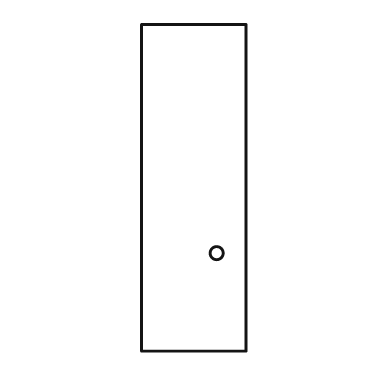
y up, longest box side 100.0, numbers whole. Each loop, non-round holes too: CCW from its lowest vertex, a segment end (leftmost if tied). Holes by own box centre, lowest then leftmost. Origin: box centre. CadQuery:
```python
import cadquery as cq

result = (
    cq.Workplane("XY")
    .moveTo(-16.0, -50.0)
    .lineTo(16.0, -50.0)
    .lineTo(16.0, 50.0)
    .lineTo(-16.0, 50.0)
    .close()
    .moveTo(7.0, -20.0)
    .circle(2.0)
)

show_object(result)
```